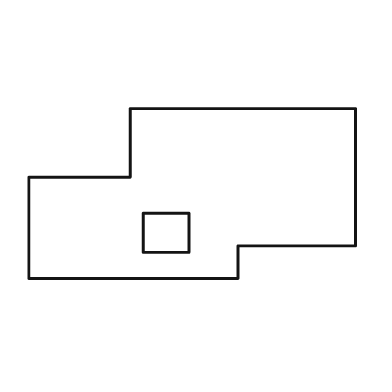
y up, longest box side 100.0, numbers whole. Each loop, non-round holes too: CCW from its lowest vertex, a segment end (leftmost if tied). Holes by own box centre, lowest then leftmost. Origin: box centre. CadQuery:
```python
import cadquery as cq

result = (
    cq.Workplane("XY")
    .moveTo(-50.0, -26.0)
    .lineTo(14.0, -26.0)
    .lineTo(14.0, -16.0)
    .lineTo(50.0, -16.0)
    .lineTo(50.0, 26.0)
    .lineTo(-19.0, 26.0)
    .lineTo(-19.0, 5.0)
    .lineTo(-50.0, 5.0)
    .close()
    .moveTo(-15.0, -18.0)
    .lineTo(-1.0, -18.0)
    .lineTo(-1.0, -6.0)
    .lineTo(-15.0, -6.0)
    .close()
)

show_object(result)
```